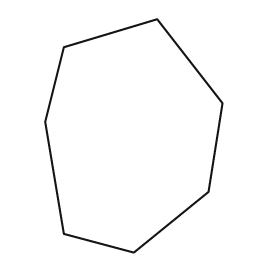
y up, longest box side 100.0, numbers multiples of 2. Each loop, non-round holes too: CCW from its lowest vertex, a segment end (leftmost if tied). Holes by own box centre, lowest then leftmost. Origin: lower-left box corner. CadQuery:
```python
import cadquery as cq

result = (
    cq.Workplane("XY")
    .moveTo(38.0, 0.0)
    .lineTo(70.0, 26.0)
    .lineTo(76.0, 64.0)
    .lineTo(48.0, 100.0)
    .lineTo(8.0, 88.0)
    .lineTo(0.0, 56.0)
    .lineTo(8.0, 8.0)
    .close()
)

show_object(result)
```